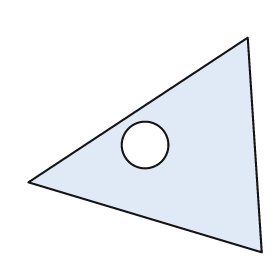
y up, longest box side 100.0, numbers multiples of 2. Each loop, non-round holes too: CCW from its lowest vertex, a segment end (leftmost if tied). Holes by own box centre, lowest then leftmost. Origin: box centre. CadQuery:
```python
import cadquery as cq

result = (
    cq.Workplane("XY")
    .moveTo(50.0, -46.0)
    .lineTo(44.0, 46.0)
    .lineTo(-50.0, -16.0)
    .close()
    .moveTo(0.0, 0.0)
    .circle(10.0)
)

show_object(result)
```